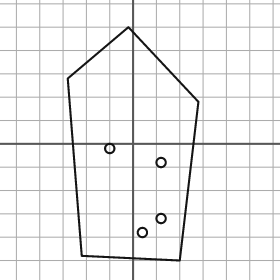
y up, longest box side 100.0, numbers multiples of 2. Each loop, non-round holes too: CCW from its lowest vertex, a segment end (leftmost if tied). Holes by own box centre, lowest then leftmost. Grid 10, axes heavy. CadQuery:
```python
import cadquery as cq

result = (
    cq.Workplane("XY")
    .moveTo(20.0, -50.0)
    .lineTo(28.0, 18.0)
    .lineTo(-2.0, 50.0)
    .lineTo(-28.0, 28.0)
    .lineTo(-22.0, -48.0)
    .close()
    .moveTo(4.0, -38.0)
    .circle(2.0)
    .moveTo(12.0, -32.0)
    .circle(2.0)
    .moveTo(12.0, -8.0)
    .circle(2.0)
    .moveTo(-10.0, -2.0)
    .circle(2.0)
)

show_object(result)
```